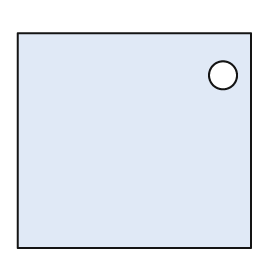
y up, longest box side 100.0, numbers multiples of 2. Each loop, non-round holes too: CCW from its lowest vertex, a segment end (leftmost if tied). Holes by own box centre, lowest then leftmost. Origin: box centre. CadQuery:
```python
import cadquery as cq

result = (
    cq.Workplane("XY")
    .moveTo(-50.0, -46.0)
    .lineTo(50.0, -46.0)
    .lineTo(50.0, 46.0)
    .lineTo(-50.0, 46.0)
    .close()
    .moveTo(38.0, 28.0)
    .circle(6.0)
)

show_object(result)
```